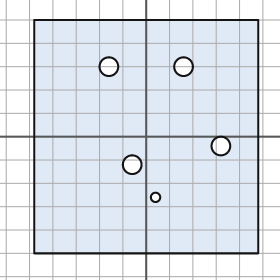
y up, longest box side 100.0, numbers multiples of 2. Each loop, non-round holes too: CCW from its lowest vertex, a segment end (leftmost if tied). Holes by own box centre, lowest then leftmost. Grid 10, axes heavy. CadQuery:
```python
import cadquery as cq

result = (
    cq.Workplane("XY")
    .moveTo(-48.0, -50.0)
    .lineTo(48.0, -50.0)
    .lineTo(48.0, 50.0)
    .lineTo(-48.0, 50.0)
    .close()
    .moveTo(4.0, -26.0)
    .circle(2.0)
    .moveTo(-6.0, -12.0)
    .circle(4.0)
    .moveTo(32.0, -4.0)
    .circle(4.0)
    .moveTo(-16.0, 30.0)
    .circle(4.0)
    .moveTo(16.0, 30.0)
    .circle(4.0)
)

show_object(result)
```